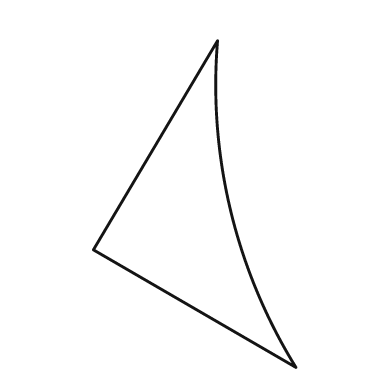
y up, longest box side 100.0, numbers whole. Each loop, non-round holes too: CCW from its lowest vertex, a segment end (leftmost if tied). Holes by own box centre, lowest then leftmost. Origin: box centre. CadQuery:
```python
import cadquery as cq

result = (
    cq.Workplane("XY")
    .moveTo(31.0, -50.0)
    .threePointArc((11.0, -2.0), (7.0, 50.0))
    .lineTo(-31.0, -14.0)
    .close()
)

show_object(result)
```